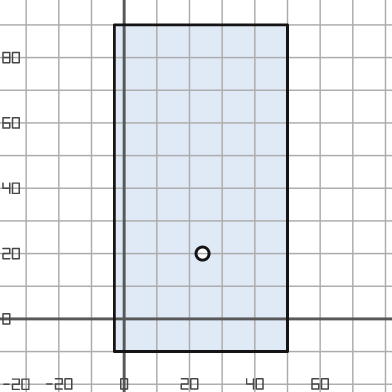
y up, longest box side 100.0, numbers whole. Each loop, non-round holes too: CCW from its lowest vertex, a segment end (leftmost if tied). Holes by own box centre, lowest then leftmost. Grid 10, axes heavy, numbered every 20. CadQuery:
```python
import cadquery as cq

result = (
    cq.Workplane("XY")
    .moveTo(-3.0, -10.0)
    .lineTo(50.0, -10.0)
    .lineTo(50.0, 90.0)
    .lineTo(-3.0, 90.0)
    .close()
    .moveTo(24.0, 20.0)
    .circle(2.0)
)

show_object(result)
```